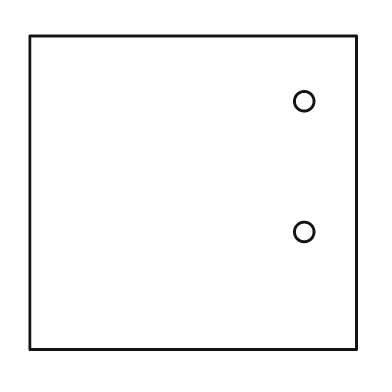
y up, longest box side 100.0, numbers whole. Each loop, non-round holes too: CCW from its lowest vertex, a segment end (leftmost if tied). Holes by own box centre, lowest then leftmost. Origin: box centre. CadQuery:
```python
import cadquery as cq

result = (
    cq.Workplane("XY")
    .moveTo(-50.0, -48.0)
    .lineTo(50.0, -48.0)
    .lineTo(50.0, 48.0)
    .lineTo(-50.0, 48.0)
    .close()
    .moveTo(34.0, -12.0)
    .circle(3.0)
    .moveTo(34.0, 28.0)
    .circle(3.0)
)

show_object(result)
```